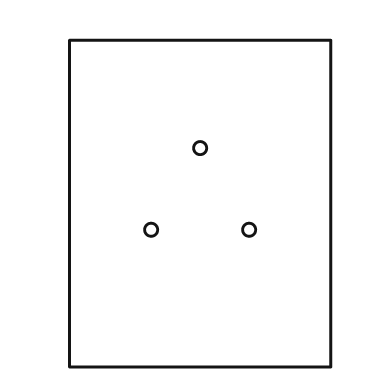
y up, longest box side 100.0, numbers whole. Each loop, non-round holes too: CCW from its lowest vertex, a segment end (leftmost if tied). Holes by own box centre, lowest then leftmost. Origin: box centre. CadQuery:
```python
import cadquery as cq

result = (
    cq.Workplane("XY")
    .moveTo(-40.0, -50.0)
    .lineTo(40.0, -50.0)
    .lineTo(40.0, 50.0)
    .lineTo(-40.0, 50.0)
    .close()
    .moveTo(-15.0, -8.0)
    .circle(2.0)
    .moveTo(15.0, -8.0)
    .circle(2.0)
    .moveTo(0.0, 17.0)
    .circle(2.0)
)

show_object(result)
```